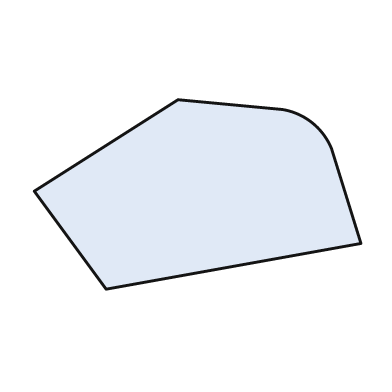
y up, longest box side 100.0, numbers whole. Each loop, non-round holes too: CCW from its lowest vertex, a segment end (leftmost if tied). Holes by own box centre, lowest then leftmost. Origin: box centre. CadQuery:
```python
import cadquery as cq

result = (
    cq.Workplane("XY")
    .moveTo(-28.0, -29.0)
    .lineTo(50.0, -15.0)
    .lineTo(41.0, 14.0)
    .threePointArc((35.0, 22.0), (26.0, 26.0))
    .lineTo(-6.0, 29.0)
    .lineTo(-50.0, 1.0)
    .close()
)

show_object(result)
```